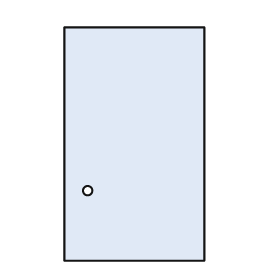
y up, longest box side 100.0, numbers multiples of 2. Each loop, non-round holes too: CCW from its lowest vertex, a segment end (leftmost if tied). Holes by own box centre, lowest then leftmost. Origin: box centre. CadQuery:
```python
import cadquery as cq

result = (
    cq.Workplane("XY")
    .moveTo(-30.0, -50.0)
    .lineTo(30.0, -50.0)
    .lineTo(30.0, 50.0)
    .lineTo(-30.0, 50.0)
    .close()
    .moveTo(-20.0, -20.0)
    .circle(2.0)
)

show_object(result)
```